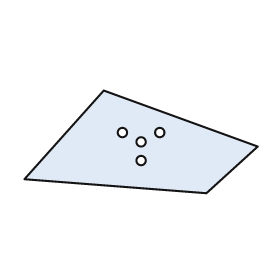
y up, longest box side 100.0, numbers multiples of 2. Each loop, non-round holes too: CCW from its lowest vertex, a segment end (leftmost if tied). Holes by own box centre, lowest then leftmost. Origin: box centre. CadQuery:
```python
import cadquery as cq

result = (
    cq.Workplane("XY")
    .moveTo(28.0, -22.0)
    .lineTo(50.0, -2.0)
    .lineTo(-16.0, 22.0)
    .lineTo(-50.0, -16.0)
    .close()
    .moveTo(0.0, -8.0)
    .circle(2.0)
    .moveTo(0.0, 0.0)
    .circle(2.0)
    .moveTo(-8.0, 4.0)
    .circle(2.0)
    .moveTo(8.0, 4.0)
    .circle(2.0)
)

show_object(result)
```